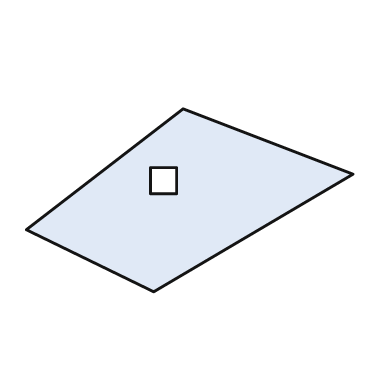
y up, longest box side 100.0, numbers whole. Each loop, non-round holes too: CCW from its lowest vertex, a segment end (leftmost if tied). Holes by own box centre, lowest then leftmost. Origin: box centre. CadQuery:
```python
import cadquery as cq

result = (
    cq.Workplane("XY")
    .moveTo(-11.0, -28.0)
    .lineTo(50.0, 8.0)
    .lineTo(-2.0, 28.0)
    .lineTo(-50.0, -9.0)
    .close()
    .moveTo(-12.0, 2.0)
    .lineTo(-4.0, 2.0)
    .lineTo(-4.0, 10.0)
    .lineTo(-12.0, 10.0)
    .close()
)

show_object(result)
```